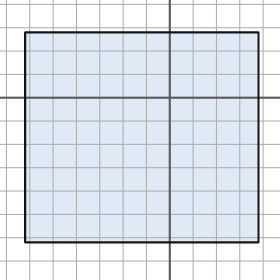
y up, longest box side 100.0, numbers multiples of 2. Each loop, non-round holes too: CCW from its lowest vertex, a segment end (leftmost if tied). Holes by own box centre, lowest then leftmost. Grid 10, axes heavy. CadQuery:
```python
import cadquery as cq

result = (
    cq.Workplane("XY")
    .moveTo(-62.0, -62.0)
    .lineTo(38.0, -62.0)
    .lineTo(38.0, 28.0)
    .lineTo(-62.0, 28.0)
    .close()
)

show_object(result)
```